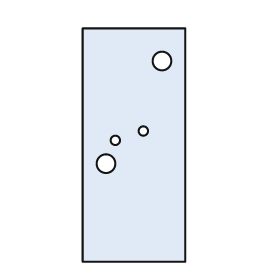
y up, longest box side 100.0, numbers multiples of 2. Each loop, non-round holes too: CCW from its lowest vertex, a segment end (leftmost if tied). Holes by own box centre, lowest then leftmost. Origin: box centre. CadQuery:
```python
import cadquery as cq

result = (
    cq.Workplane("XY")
    .moveTo(-22.0, -50.0)
    .lineTo(22.0, -50.0)
    .lineTo(22.0, 50.0)
    .lineTo(-22.0, 50.0)
    .close()
    .moveTo(-12.0, -8.0)
    .circle(4.0)
    .moveTo(-8.0, 2.0)
    .circle(2.0)
    .moveTo(4.0, 6.0)
    .circle(2.0)
    .moveTo(12.0, 36.0)
    .circle(4.0)
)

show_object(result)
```